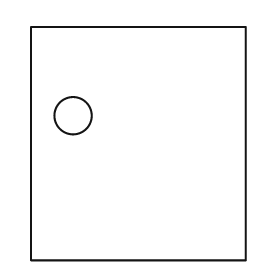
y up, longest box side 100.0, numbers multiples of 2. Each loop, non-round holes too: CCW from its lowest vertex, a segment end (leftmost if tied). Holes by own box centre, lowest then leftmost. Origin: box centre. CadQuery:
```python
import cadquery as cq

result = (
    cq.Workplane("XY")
    .moveTo(-46.0, -50.0)
    .lineTo(46.0, -50.0)
    .lineTo(46.0, 50.0)
    .lineTo(-46.0, 50.0)
    .close()
    .moveTo(-28.0, 12.0)
    .circle(8.0)
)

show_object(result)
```